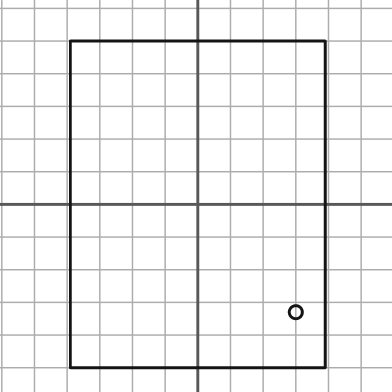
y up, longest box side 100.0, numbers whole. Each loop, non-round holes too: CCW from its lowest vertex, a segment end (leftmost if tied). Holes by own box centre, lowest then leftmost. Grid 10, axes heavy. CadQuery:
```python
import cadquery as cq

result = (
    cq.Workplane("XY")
    .moveTo(-39.0, -50.0)
    .lineTo(39.0, -50.0)
    .lineTo(39.0, 50.0)
    .lineTo(-39.0, 50.0)
    .close()
    .moveTo(30.0, -33.0)
    .circle(2.0)
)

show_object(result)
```